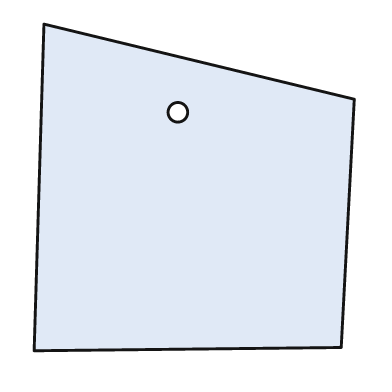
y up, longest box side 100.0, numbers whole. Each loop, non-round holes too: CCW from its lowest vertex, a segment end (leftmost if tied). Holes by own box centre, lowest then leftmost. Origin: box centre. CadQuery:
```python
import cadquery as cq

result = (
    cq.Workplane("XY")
    .moveTo(-49.0, -50.0)
    .lineTo(45.0, -49.0)
    .lineTo(49.0, 27.0)
    .lineTo(-46.0, 50.0)
    .close()
    .moveTo(-5.0, 23.0)
    .circle(3.0)
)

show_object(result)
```